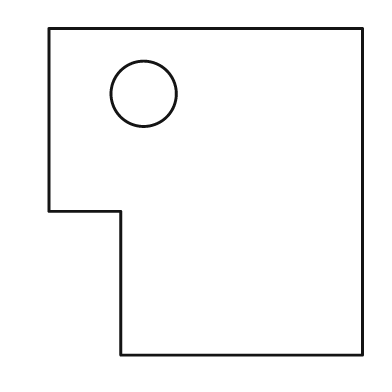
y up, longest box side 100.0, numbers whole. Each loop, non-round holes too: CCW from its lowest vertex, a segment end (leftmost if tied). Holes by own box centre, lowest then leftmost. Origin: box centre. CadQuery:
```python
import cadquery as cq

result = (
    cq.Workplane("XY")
    .moveTo(-26.0, -50.0)
    .lineTo(48.0, -50.0)
    .lineTo(48.0, 50.0)
    .lineTo(-48.0, 50.0)
    .lineTo(-48.0, -6.0)
    .lineTo(-26.0, -6.0)
    .close()
    .moveTo(-19.0, 30.0)
    .circle(10.0)
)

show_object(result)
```